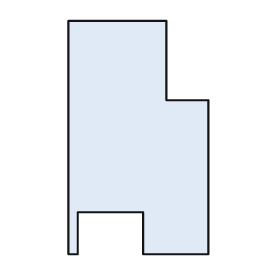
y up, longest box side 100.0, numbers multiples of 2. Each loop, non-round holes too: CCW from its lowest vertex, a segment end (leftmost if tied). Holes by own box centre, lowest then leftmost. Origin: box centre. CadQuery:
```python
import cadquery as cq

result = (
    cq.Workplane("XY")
    .moveTo(-30.0, -50.0)
    .lineTo(-26.0, -50.0)
    .lineTo(-26.0, -32.0)
    .lineTo(2.0, -32.0)
    .lineTo(2.0, -50.0)
    .lineTo(30.0, -50.0)
    .lineTo(30.0, 16.0)
    .lineTo(12.0, 16.0)
    .lineTo(12.0, 50.0)
    .lineTo(-30.0, 50.0)
    .close()
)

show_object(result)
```